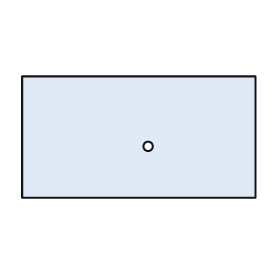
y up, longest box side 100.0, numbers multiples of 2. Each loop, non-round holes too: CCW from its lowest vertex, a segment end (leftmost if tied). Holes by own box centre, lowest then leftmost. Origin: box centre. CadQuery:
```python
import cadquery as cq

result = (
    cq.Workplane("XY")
    .moveTo(-50.0, -26.0)
    .lineTo(50.0, -26.0)
    .lineTo(50.0, 26.0)
    .lineTo(-50.0, 26.0)
    .close()
    .moveTo(4.0, -4.0)
    .circle(2.0)
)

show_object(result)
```